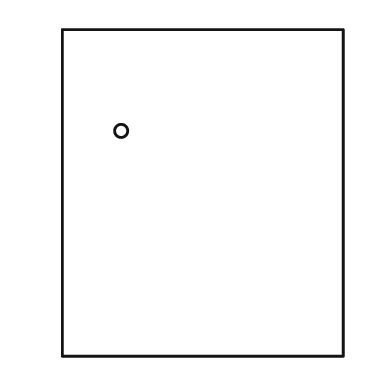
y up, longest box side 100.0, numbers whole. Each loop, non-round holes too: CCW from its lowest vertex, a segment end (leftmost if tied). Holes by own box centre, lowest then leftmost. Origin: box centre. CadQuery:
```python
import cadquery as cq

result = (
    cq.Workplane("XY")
    .moveTo(-43.0, -50.0)
    .lineTo(43.0, -50.0)
    .lineTo(43.0, 50.0)
    .lineTo(-43.0, 50.0)
    .close()
    .moveTo(-25.0, 19.0)
    .circle(2.0)
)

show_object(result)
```